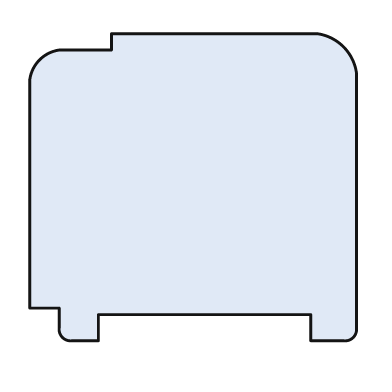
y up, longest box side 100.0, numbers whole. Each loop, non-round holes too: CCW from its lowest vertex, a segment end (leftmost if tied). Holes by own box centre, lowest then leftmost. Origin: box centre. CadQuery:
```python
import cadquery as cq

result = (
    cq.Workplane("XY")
    .moveTo(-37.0, -47.0)
    .lineTo(-29.0, -47.0)
    .lineTo(-29.0, -39.0)
    .lineTo(36.0, -39.0)
    .lineTo(36.0, -47.0)
    .lineTo(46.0, -47.0)
    .threePointArc((49.0, -46.0), (50.0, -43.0))
    .lineTo(50.0, 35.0)
    .threePointArc((46.0, 43.0), (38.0, 47.0))
    .lineTo(-25.0, 47.0)
    .lineTo(-25.0, 42.0)
    .lineTo(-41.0, 42.0)
    .threePointArc((-47.0, 39.0), (-50.0, 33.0))
    .lineTo(-50.0, -37.0)
    .lineTo(-41.0, -37.0)
    .lineTo(-41.0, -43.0)
    .threePointArc((-40.0, -46.0), (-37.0, -47.0))
    .close()
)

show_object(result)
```